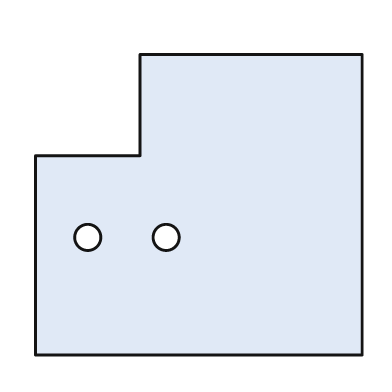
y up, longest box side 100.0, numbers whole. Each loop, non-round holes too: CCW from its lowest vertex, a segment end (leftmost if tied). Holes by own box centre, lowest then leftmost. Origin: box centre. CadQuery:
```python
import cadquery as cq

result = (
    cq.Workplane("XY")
    .moveTo(-50.0, -46.0)
    .lineTo(50.0, -46.0)
    .lineTo(50.0, 46.0)
    .lineTo(-18.0, 46.0)
    .lineTo(-18.0, 15.0)
    .lineTo(-50.0, 15.0)
    .close()
    .moveTo(-34.0, -10.0)
    .circle(4.0)
    .moveTo(-10.0, -10.0)
    .circle(4.0)
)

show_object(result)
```